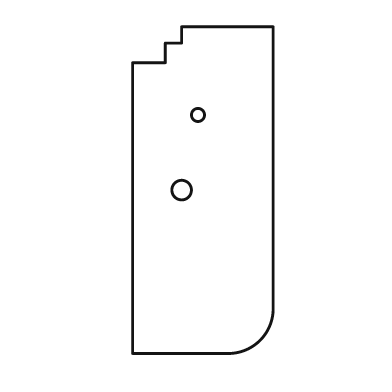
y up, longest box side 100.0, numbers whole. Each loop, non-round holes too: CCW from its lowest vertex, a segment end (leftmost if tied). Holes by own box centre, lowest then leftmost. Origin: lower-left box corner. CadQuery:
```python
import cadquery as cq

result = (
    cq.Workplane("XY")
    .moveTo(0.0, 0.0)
    .lineTo(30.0, 0.0)
    .threePointArc((39.0, 4.0), (43.0, 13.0))
    .lineTo(43.0, 100.0)
    .lineTo(15.0, 100.0)
    .lineTo(15.0, 95.0)
    .lineTo(10.0, 95.0)
    .lineTo(10.0, 89.0)
    .lineTo(0.0, 89.0)
    .close()
    .moveTo(15.0, 50.0)
    .circle(3.0)
    .moveTo(20.0, 73.0)
    .circle(2.0)
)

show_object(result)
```